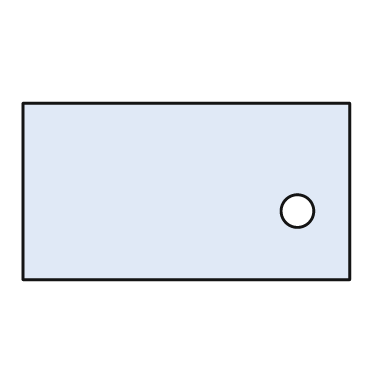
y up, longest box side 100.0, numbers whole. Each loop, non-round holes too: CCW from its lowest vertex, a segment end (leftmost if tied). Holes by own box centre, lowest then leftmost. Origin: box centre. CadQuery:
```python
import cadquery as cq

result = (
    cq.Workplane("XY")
    .moveTo(-50.0, -27.0)
    .lineTo(50.0, -27.0)
    .lineTo(50.0, 27.0)
    .lineTo(-50.0, 27.0)
    .close()
    .moveTo(34.0, -6.0)
    .circle(5.0)
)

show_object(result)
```